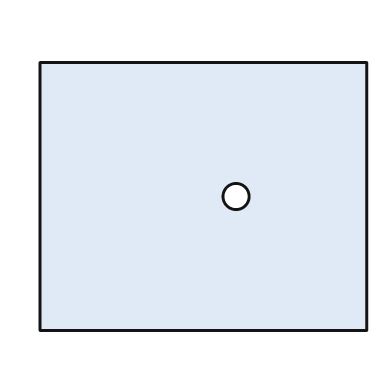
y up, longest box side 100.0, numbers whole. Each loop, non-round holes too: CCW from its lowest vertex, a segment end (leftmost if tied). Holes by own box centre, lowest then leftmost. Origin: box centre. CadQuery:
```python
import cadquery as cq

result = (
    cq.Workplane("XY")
    .moveTo(-50.0, -41.0)
    .lineTo(50.0, -41.0)
    .lineTo(50.0, 41.0)
    .lineTo(-50.0, 41.0)
    .close()
    .moveTo(10.0, 0.0)
    .circle(4.0)
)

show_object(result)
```